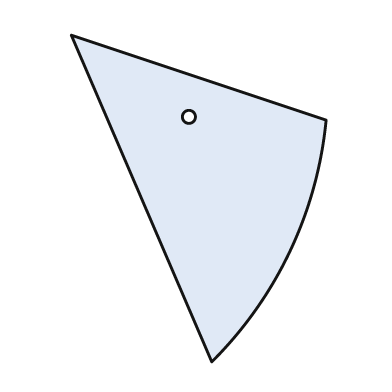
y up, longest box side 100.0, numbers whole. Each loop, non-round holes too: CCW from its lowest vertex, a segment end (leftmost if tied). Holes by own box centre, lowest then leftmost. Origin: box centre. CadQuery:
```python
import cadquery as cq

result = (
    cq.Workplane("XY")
    .moveTo(4.0, -50.0)
    .threePointArc((28.0, -16.0), (39.0, 24.0))
    .lineTo(-39.0, 50.0)
    .close()
    .moveTo(-3.0, 25.0)
    .circle(2.0)
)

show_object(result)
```